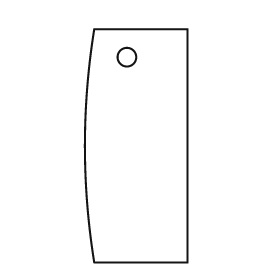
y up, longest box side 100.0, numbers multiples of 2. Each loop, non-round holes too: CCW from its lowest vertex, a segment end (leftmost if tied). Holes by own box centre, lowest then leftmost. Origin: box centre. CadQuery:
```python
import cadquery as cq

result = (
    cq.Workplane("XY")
    .moveTo(-18.0, -50.0)
    .lineTo(22.0, -50.0)
    .lineTo(22.0, 50.0)
    .lineTo(-18.0, 50.0)
    .threePointArc((-22.0, 0.0), (-18.0, -50.0))
    .close()
    .moveTo(-4.0, 38.0)
    .circle(4.0)
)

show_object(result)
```